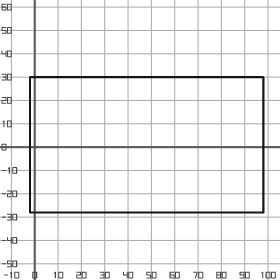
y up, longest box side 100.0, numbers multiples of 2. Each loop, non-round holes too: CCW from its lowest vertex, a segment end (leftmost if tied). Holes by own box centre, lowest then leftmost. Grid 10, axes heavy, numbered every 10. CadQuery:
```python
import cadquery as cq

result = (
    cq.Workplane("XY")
    .moveTo(-2.0, -28.0)
    .lineTo(98.0, -28.0)
    .lineTo(98.0, 30.0)
    .lineTo(-2.0, 30.0)
    .close()
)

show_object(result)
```